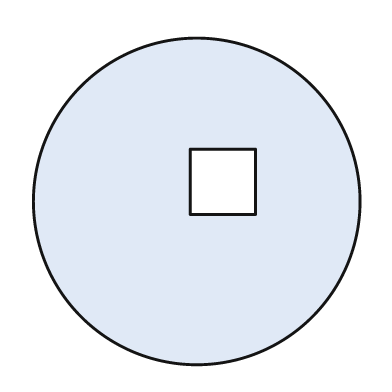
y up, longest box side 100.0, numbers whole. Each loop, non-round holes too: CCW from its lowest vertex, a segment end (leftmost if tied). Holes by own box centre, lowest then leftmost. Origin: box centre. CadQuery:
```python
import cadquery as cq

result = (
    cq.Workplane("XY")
    .moveTo(0.0, 0.0)
    .circle(50.0)
    .moveTo(-2.0, -4.0)
    .lineTo(18.0, -4.0)
    .lineTo(18.0, 16.0)
    .lineTo(-2.0, 16.0)
    .close()
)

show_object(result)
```